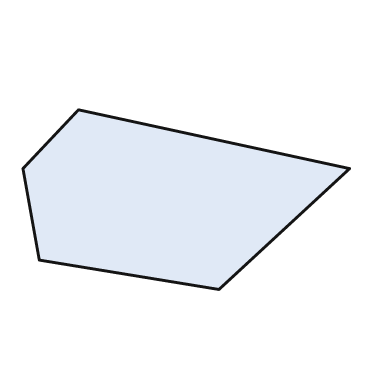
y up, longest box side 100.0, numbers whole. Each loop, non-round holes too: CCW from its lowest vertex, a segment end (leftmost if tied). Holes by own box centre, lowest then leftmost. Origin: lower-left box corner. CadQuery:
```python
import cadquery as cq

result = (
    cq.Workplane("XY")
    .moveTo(60.0, 0.0)
    .lineTo(100.0, 37.0)
    .lineTo(17.0, 55.0)
    .lineTo(0.0, 37.0)
    .lineTo(5.0, 9.0)
    .close()
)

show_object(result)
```